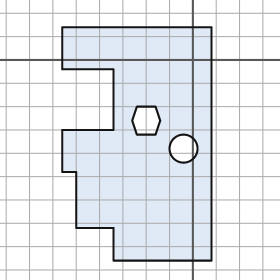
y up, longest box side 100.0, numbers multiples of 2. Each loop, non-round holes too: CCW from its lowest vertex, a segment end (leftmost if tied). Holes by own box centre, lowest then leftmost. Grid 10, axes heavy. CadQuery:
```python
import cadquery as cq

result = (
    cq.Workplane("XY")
    .moveTo(-34.0, -86.0)
    .lineTo(8.0, -86.0)
    .lineTo(8.0, 14.0)
    .lineTo(-56.0, 14.0)
    .lineTo(-56.0, -4.0)
    .lineTo(-34.0, -4.0)
    .lineTo(-34.0, -30.0)
    .lineTo(-56.0, -30.0)
    .lineTo(-56.0, -48.0)
    .lineTo(-50.0, -48.0)
    .lineTo(-50.0, -72.0)
    .lineTo(-34.0, -72.0)
    .close()
    .moveTo(-4.0, -38.0)
    .circle(6.0)
    .moveTo(-24.0, -32.0)
    .lineTo(-16.0, -32.0)
    .lineTo(-14.0, -26.0)
    .lineTo(-16.0, -20.0)
    .lineTo(-24.0, -20.0)
    .lineTo(-26.0, -26.0)
    .close()
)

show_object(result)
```